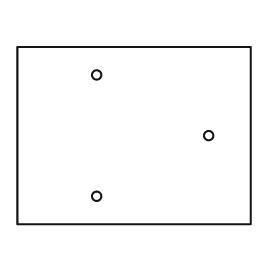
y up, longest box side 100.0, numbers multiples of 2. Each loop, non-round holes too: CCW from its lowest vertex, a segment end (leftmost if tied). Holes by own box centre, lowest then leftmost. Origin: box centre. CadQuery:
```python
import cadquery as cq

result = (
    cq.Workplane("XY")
    .moveTo(-50.0, -38.0)
    .lineTo(50.0, -38.0)
    .lineTo(50.0, 38.0)
    .lineTo(-50.0, 38.0)
    .close()
    .moveTo(-16.0, -26.0)
    .circle(2.0)
    .moveTo(32.0, 0.0)
    .circle(2.0)
    .moveTo(-16.0, 26.0)
    .circle(2.0)
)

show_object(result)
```